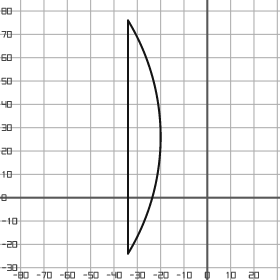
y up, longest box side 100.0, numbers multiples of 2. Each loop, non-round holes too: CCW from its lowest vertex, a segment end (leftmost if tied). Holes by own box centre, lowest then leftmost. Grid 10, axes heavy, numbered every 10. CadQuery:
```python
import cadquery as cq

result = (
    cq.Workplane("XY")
    .moveTo(-34.0, -24.0)
    .threePointArc((-20.0, 26.0), (-34.0, 76.0))
    .close()
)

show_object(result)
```